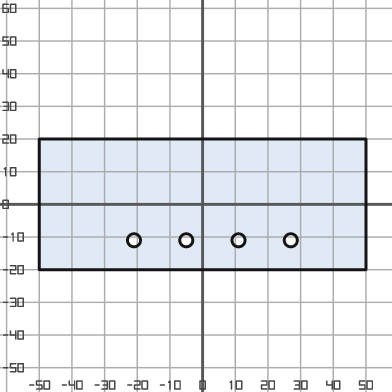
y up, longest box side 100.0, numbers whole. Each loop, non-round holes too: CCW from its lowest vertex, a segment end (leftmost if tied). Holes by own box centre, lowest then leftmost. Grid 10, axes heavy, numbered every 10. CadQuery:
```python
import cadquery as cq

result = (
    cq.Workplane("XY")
    .moveTo(-50.0, -20.0)
    .lineTo(50.0, -20.0)
    .lineTo(50.0, 20.0)
    .lineTo(-50.0, 20.0)
    .close()
    .moveTo(-21.0, -11.0)
    .circle(2.0)
    .moveTo(-5.0, -11.0)
    .circle(2.0)
    .moveTo(11.0, -11.0)
    .circle(2.0)
    .moveTo(27.0, -11.0)
    .circle(2.0)
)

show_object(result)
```